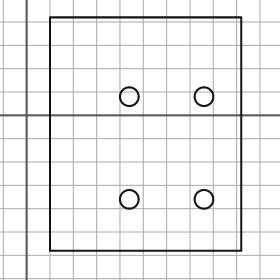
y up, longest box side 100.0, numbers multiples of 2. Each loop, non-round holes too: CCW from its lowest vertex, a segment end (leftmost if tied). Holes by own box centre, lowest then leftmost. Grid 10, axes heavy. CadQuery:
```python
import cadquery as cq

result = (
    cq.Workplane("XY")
    .moveTo(10.0, -58.0)
    .lineTo(92.0, -58.0)
    .lineTo(92.0, 42.0)
    .lineTo(10.0, 42.0)
    .close()
    .moveTo(44.0, -36.0)
    .circle(4.0)
    .moveTo(76.0, -36.0)
    .circle(4.0)
    .moveTo(44.0, 8.0)
    .circle(4.0)
    .moveTo(76.0, 8.0)
    .circle(4.0)
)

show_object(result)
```